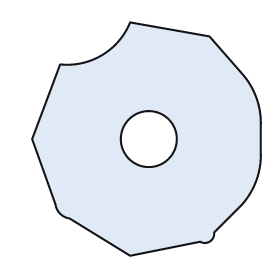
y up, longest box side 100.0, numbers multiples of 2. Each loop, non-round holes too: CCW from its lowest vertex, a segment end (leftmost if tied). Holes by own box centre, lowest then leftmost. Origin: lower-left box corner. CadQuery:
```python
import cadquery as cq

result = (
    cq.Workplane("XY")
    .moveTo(42.0, 0.0)
    .lineTo(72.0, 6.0)
    .threePointArc((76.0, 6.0), (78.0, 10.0))
    .lineTo(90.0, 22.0)
    .threePointArc((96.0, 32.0), (98.0, 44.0))
    .lineTo(98.0, 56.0)
    .threePointArc((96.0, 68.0), (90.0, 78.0))
    .lineTo(76.0, 94.0)
    .lineTo(42.0, 100.0)
    .threePointArc((30.0, 86.0), (12.0, 82.0))
    .lineTo(0.0, 50.0)
    .lineTo(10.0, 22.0)
    .threePointArc((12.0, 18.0), (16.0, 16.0))
    .close()
    .moveTo(50.0, 50.0)
    .circle(12.0)
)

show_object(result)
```